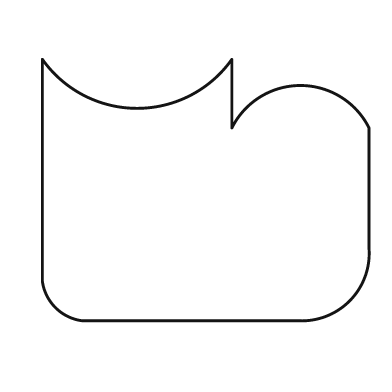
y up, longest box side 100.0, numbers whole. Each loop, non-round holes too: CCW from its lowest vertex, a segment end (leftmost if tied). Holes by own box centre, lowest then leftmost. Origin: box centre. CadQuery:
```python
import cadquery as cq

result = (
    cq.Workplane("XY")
    .moveTo(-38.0, -40.0)
    .lineTo(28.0, -40.0)
    .threePointArc((44.0, -34.0), (50.0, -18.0))
    .lineTo(50.0, 19.0)
    .threePointArc((29.0, 32.0), (8.0, 19.0))
    .lineTo(8.0, 40.0)
    .threePointArc((-21.0, 25.0), (-50.0, 40.0))
    .lineTo(-50.0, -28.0)
    .threePointArc((-46.0, -36.0), (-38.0, -40.0))
    .close()
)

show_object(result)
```